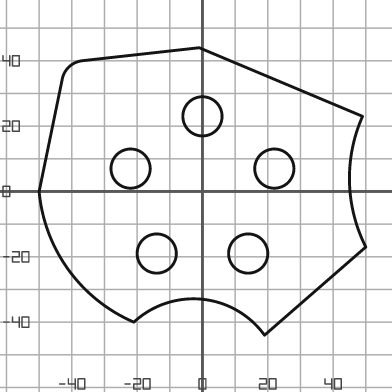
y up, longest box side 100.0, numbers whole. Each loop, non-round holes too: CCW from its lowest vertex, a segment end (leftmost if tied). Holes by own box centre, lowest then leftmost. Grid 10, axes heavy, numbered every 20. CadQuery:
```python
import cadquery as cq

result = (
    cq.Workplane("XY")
    .moveTo(19.0, -44.0)
    .lineTo(50.0, -17.0)
    .threePointArc((45.0, 3.0), (49.0, 23.0))
    .lineTo(-1.0, 44.0)
    .lineTo(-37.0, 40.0)
    .threePointArc((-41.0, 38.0), (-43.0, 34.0))
    .lineTo(-50.0, 0.0)
    .threePointArc((-41.0, -24.0), (-21.0, -40.0))
    .threePointArc((0.0, -33.0), (19.0, -44.0))
    .close()
    .moveTo(-14.0, -19.0)
    .circle(6.0)
    .moveTo(14.0, -19.0)
    .circle(6.0)
    .moveTo(-22.0, 7.0)
    .circle(6.0)
    .moveTo(22.0, 7.0)
    .circle(6.0)
    .moveTo(0.0, 23.0)
    .circle(6.0)
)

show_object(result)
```